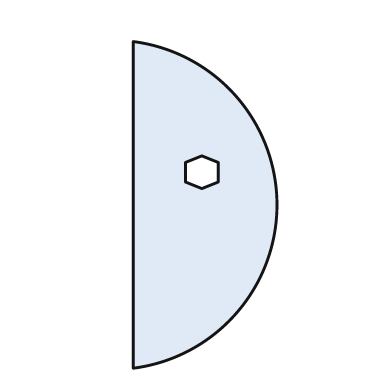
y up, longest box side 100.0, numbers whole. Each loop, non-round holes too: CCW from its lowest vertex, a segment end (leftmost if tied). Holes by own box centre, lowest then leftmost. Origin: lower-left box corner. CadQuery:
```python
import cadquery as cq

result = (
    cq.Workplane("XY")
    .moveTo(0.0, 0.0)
    .threePointArc((44.0, 50.0), (0.0, 100.0))
    .close()
    .moveTo(21.0, 55.0)
    .lineTo(26.0, 57.0)
    .lineTo(26.0, 63.0)
    .lineTo(21.0, 65.0)
    .lineTo(16.0, 63.0)
    .lineTo(16.0, 57.0)
    .close()
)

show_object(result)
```